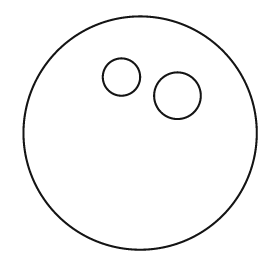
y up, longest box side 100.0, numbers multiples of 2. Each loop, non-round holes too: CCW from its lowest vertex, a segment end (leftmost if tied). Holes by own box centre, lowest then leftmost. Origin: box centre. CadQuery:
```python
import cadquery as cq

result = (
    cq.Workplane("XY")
    .moveTo(0.0, 0.0)
    .circle(50.0)
    .moveTo(16.0, 16.0)
    .circle(10.0)
    .moveTo(-8.0, 24.0)
    .circle(8.0)
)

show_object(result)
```